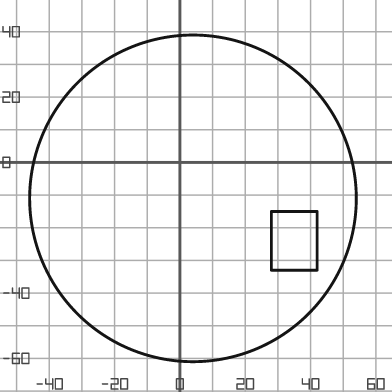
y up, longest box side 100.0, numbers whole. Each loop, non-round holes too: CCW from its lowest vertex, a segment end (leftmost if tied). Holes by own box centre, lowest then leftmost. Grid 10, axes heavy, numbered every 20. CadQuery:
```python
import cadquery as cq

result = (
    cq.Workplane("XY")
    .moveTo(4.0, -11.0)
    .circle(50.0)
    .moveTo(28.0, -33.0)
    .lineTo(42.0, -33.0)
    .lineTo(42.0, -15.0)
    .lineTo(28.0, -15.0)
    .close()
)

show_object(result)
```